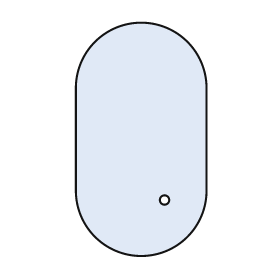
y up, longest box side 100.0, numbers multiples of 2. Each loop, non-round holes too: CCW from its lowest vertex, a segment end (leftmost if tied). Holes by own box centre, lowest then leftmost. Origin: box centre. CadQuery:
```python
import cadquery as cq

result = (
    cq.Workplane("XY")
    .moveTo(-28.0, -22.0)
    .threePointArc((0.0, -50.0), (28.0, -22.0))
    .lineTo(28.0, 22.0)
    .threePointArc((0.0, 50.0), (-28.0, 22.0))
    .close()
    .moveTo(10.0, -26.0)
    .circle(2.0)
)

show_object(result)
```